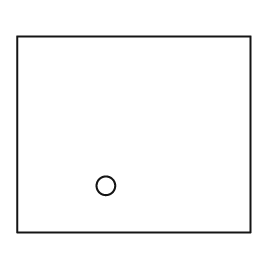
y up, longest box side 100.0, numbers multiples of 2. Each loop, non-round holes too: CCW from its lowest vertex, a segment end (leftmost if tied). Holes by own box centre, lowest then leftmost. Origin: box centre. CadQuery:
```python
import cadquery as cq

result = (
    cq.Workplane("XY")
    .moveTo(-50.0, -42.0)
    .lineTo(50.0, -42.0)
    .lineTo(50.0, 42.0)
    .lineTo(-50.0, 42.0)
    .close()
    .moveTo(-12.0, -22.0)
    .circle(4.0)
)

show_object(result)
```